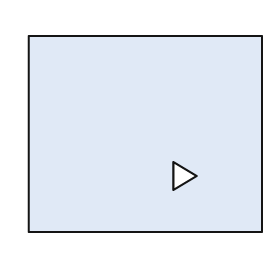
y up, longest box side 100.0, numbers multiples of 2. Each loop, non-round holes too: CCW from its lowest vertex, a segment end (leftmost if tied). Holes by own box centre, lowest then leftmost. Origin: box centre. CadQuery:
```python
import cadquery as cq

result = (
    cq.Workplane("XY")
    .moveTo(-50.0, -42.0)
    .lineTo(50.0, -42.0)
    .lineTo(50.0, 42.0)
    .lineTo(-50.0, 42.0)
    .close()
    .moveTo(12.0, -24.0)
    .lineTo(22.0, -18.0)
    .lineTo(12.0, -12.0)
    .close()
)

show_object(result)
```